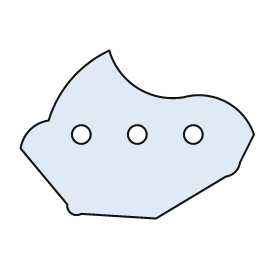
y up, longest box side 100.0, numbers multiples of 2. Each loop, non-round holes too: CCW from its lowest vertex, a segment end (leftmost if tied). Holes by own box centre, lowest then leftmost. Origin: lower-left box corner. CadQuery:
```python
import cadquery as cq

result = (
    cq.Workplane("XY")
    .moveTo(58.0, 0.0)
    .lineTo(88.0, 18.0)
    .threePointArc((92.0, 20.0), (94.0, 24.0))
    .lineTo(100.0, 36.0)
    .threePointArc((88.0, 50.0), (70.0, 52.0))
    .threePointArc((50.0, 56.0), (38.0, 72.0))
    .threePointArc((22.0, 60.0), (12.0, 42.0))
    .threePointArc((4.0, 38.0), (0.0, 30.0))
    .lineTo(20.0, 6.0)
    .threePointArc((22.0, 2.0), (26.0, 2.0))
    .close()
    .moveTo(26.0, 36.0)
    .circle(4.0)
    .moveTo(50.0, 36.0)
    .circle(4.0)
    .moveTo(74.0, 36.0)
    .circle(4.0)
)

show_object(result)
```